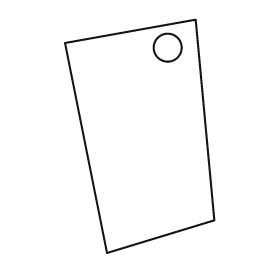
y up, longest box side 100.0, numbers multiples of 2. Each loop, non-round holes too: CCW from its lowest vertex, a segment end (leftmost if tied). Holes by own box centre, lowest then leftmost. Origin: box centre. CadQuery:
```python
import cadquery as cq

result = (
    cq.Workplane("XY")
    .moveTo(-14.0, -50.0)
    .lineTo(32.0, -36.0)
    .lineTo(24.0, 50.0)
    .lineTo(-32.0, 40.0)
    .close()
    .moveTo(12.0, 38.0)
    .circle(6.0)
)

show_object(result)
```